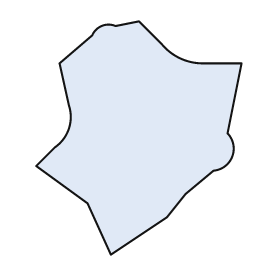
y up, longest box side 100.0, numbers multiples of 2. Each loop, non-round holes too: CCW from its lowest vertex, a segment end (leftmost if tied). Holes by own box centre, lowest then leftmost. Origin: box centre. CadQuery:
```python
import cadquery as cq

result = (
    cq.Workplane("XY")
    .moveTo(-12.0, -50.0)
    .lineTo(12.0, -34.0)
    .lineTo(20.0, -24.0)
    .lineTo(32.0, -14.0)
    .threePointArc((40.0, -8.0), (38.0, 2.0))
    .lineTo(44.0, 32.0)
    .lineTo(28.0, 32.0)
    .threePointArc((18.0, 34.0), (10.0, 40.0))
    .lineTo(0.0, 50.0)
    .lineTo(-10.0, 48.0)
    .threePointArc((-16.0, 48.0), (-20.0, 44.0))
    .lineTo(-34.0, 32.0)
    .lineTo(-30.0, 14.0)
    .threePointArc((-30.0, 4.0), (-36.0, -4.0))
    .lineTo(-44.0, -12.0)
    .lineTo(-22.0, -28.0)
    .close()
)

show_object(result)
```